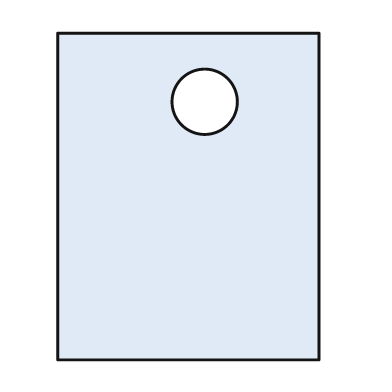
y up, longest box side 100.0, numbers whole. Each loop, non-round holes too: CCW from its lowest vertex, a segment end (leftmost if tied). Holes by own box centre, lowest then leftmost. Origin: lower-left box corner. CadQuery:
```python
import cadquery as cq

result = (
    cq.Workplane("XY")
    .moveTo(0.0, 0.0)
    .lineTo(80.0, 0.0)
    .lineTo(80.0, 100.0)
    .lineTo(0.0, 100.0)
    .close()
    .moveTo(45.0, 79.0)
    .circle(10.0)
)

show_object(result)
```